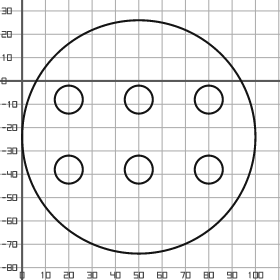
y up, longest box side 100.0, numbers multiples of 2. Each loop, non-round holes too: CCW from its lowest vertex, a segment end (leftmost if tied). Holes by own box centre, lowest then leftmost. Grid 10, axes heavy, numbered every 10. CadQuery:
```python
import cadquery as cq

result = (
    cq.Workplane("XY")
    .moveTo(50.0, -24.0)
    .circle(50.0)
    .moveTo(20.0, -38.0)
    .circle(6.0)
    .moveTo(50.0, -38.0)
    .circle(6.0)
    .moveTo(80.0, -38.0)
    .circle(6.0)
    .moveTo(20.0, -8.0)
    .circle(6.0)
    .moveTo(50.0, -8.0)
    .circle(6.0)
    .moveTo(80.0, -8.0)
    .circle(6.0)
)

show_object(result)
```